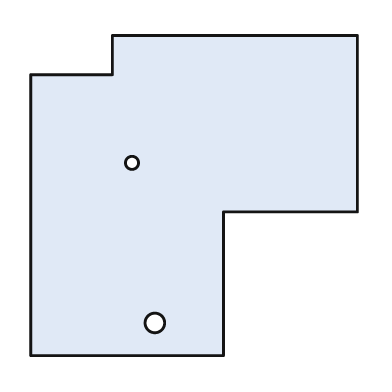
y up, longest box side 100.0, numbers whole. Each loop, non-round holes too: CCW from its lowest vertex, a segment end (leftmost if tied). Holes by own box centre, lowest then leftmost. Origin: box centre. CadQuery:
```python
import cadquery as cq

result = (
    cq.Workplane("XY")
    .moveTo(-50.0, -49.0)
    .lineTo(9.0, -49.0)
    .lineTo(9.0, -5.0)
    .lineTo(50.0, -5.0)
    .lineTo(50.0, 49.0)
    .lineTo(-25.0, 49.0)
    .lineTo(-25.0, 37.0)
    .lineTo(-50.0, 37.0)
    .close()
    .moveTo(-12.0, -39.0)
    .circle(3.0)
    .moveTo(-19.0, 10.0)
    .circle(2.0)
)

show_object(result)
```